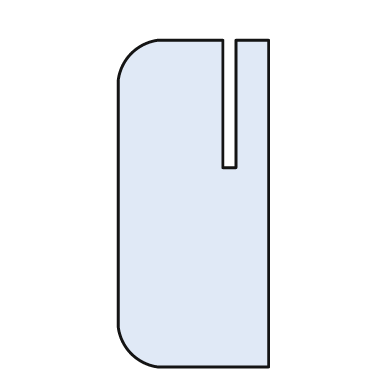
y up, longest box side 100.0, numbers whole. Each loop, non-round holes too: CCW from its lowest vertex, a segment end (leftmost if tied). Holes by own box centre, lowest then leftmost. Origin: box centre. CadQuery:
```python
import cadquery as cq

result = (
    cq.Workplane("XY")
    .moveTo(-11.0, -50.0)
    .lineTo(23.0, -50.0)
    .lineTo(23.0, 50.0)
    .lineTo(13.0, 50.0)
    .lineTo(13.0, 11.0)
    .lineTo(9.0, 11.0)
    .lineTo(9.0, 50.0)
    .lineTo(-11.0, 50.0)
    .threePointArc((-19.0, 46.0), (-23.0, 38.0))
    .lineTo(-23.0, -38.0)
    .threePointArc((-19.0, -46.0), (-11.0, -50.0))
    .close()
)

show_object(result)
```